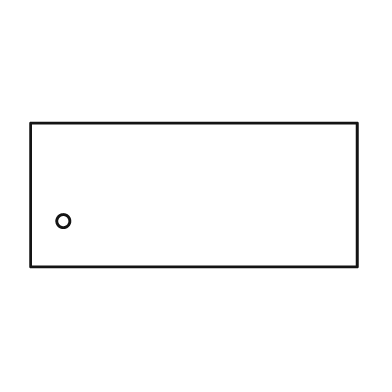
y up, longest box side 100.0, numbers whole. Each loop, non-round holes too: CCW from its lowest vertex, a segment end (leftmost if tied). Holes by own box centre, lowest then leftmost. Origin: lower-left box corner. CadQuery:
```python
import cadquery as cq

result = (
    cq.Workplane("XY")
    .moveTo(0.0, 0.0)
    .lineTo(100.0, 0.0)
    .lineTo(100.0, 44.0)
    .lineTo(0.0, 44.0)
    .close()
    .moveTo(10.0, 14.0)
    .circle(2.0)
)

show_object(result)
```